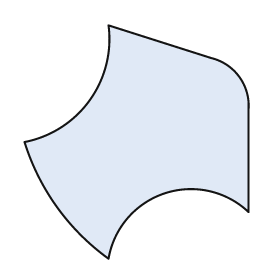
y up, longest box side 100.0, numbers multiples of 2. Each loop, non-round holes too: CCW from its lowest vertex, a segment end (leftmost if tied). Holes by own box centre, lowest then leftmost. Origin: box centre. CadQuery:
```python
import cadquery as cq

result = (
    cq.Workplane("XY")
    .moveTo(-12.0, -50.0)
    .threePointArc((12.0, -22.0), (48.0, -30.0))
    .lineTo(48.0, 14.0)
    .threePointArc((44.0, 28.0), (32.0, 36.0))
    .lineTo(-12.0, 50.0)
    .threePointArc((-20.0, 18.0), (-48.0, 0.0))
    .threePointArc((-34.0, -28.0), (-12.0, -50.0))
    .close()
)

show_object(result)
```